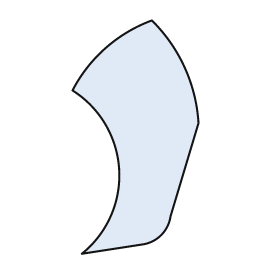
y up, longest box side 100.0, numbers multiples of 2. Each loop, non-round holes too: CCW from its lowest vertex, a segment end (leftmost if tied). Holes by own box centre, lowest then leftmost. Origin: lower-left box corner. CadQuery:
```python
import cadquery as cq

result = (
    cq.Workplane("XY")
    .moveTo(4.0, 0.0)
    .lineTo(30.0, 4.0)
    .threePointArc((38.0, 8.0), (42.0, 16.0))
    .lineTo(54.0, 56.0)
    .threePointArc((48.0, 80.0), (34.0, 100.0))
    .threePointArc((14.0, 88.0), (0.0, 70.0))
    .threePointArc((20.0, 36.0), (4.0, 0.0))
    .close()
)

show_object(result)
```